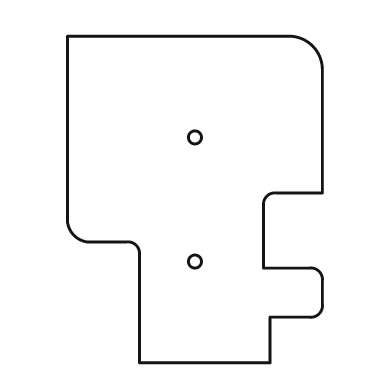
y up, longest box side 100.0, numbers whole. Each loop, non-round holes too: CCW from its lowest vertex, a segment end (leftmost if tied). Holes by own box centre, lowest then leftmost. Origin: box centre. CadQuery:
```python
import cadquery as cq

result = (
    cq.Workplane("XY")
    .moveTo(-17.0, -50.0)
    .lineTo(23.0, -50.0)
    .lineTo(23.0, -36.0)
    .lineTo(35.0, -36.0)
    .threePointArc((38.0, -35.0), (39.0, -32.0))
    .lineTo(39.0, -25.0)
    .threePointArc((38.0, -22.0), (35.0, -21.0))
    .lineTo(21.0, -21.0)
    .lineTo(21.0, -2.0)
    .threePointArc((22.0, 1.0), (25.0, 2.0))
    .lineTo(39.0, 2.0)
    .lineTo(39.0, 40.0)
    .threePointArc((36.0, 47.0), (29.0, 50.0))
    .lineTo(-39.0, 50.0)
    .lineTo(-39.0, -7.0)
    .threePointArc((-37.0, -11.0), (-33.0, -13.0))
    .lineTo(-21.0, -13.0)
    .threePointArc((-18.0, -14.0), (-17.0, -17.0))
    .close()
    .moveTo(0.0, -19.0)
    .circle(2.0)
    .moveTo(0.0, 19.0)
    .circle(2.0)
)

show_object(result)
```